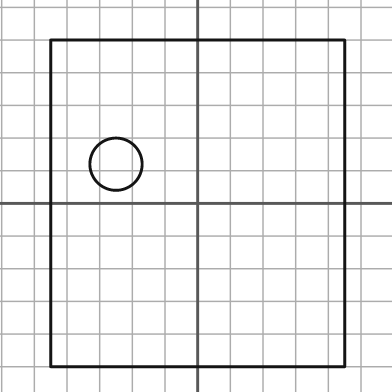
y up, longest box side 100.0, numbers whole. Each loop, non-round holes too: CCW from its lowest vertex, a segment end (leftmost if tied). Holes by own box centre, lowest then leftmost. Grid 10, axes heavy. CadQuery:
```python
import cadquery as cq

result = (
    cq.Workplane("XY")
    .moveTo(-45.0, -50.0)
    .lineTo(45.0, -50.0)
    .lineTo(45.0, 50.0)
    .lineTo(-45.0, 50.0)
    .close()
    .moveTo(-25.0, 12.0)
    .circle(8.0)
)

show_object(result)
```